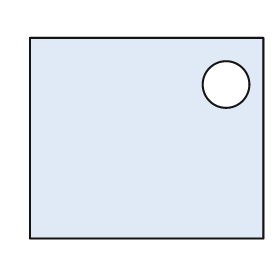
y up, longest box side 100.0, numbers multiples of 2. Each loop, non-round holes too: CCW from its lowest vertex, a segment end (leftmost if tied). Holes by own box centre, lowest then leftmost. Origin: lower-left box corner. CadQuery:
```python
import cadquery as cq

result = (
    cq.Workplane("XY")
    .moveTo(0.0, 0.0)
    .lineTo(100.0, 0.0)
    .lineTo(100.0, 86.0)
    .lineTo(0.0, 86.0)
    .close()
    .moveTo(84.0, 66.0)
    .circle(10.0)
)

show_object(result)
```